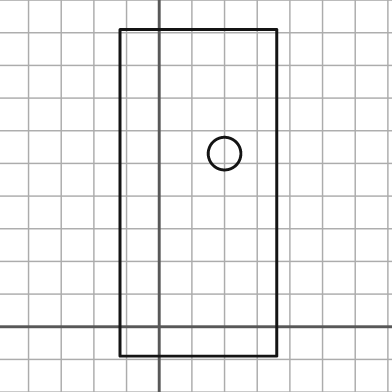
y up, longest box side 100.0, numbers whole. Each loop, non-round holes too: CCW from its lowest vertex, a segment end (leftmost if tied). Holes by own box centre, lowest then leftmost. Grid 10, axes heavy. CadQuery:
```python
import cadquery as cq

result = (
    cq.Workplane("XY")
    .moveTo(-12.0, -9.0)
    .lineTo(36.0, -9.0)
    .lineTo(36.0, 91.0)
    .lineTo(-12.0, 91.0)
    .close()
    .moveTo(20.0, 53.0)
    .circle(5.0)
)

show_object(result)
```